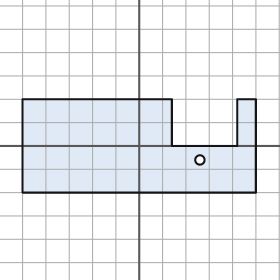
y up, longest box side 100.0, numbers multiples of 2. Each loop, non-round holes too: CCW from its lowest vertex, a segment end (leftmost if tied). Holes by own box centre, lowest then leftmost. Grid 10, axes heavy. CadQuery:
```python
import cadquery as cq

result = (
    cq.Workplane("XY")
    .moveTo(-50.0, -20.0)
    .lineTo(50.0, -20.0)
    .lineTo(50.0, 20.0)
    .lineTo(42.0, 20.0)
    .lineTo(42.0, 0.0)
    .lineTo(14.0, 0.0)
    .lineTo(14.0, 20.0)
    .lineTo(-50.0, 20.0)
    .close()
    .moveTo(26.0, -6.0)
    .circle(2.0)
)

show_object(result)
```